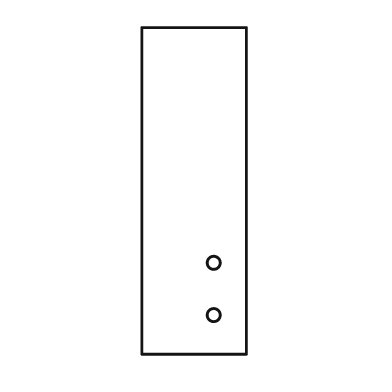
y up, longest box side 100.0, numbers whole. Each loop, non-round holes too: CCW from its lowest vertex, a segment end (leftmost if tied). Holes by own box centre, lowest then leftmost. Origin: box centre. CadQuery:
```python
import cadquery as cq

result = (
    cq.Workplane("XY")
    .moveTo(-16.0, -50.0)
    .lineTo(16.0, -50.0)
    .lineTo(16.0, 50.0)
    .lineTo(-16.0, 50.0)
    .close()
    .moveTo(6.0, -38.0)
    .circle(2.0)
    .moveTo(6.0, -22.0)
    .circle(2.0)
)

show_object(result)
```